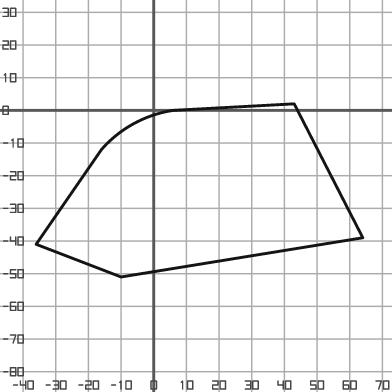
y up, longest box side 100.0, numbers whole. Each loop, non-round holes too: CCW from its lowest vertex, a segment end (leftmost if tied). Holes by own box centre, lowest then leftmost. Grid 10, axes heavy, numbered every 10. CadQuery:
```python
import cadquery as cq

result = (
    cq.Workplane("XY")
    .moveTo(-10.0, -51.0)
    .lineTo(64.0, -39.0)
    .lineTo(43.0, 2.0)
    .lineTo(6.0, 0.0)
    .threePointArc((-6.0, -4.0), (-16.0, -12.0))
    .lineTo(-36.0, -41.0)
    .close()
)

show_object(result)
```